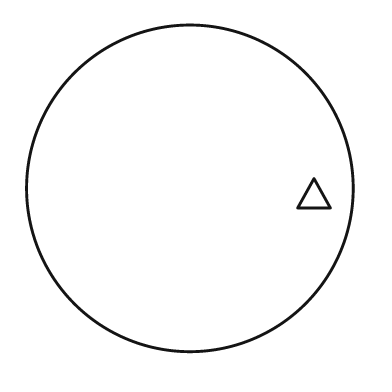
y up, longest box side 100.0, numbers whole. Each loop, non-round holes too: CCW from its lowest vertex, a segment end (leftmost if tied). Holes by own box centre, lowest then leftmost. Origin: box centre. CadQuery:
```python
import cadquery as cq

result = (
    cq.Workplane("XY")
    .moveTo(0.0, 0.0)
    .circle(50.0)
    .moveTo(33.0, -6.0)
    .lineTo(43.0, -6.0)
    .lineTo(38.0, 3.0)
    .close()
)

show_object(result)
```